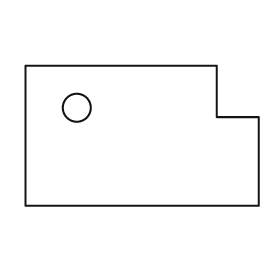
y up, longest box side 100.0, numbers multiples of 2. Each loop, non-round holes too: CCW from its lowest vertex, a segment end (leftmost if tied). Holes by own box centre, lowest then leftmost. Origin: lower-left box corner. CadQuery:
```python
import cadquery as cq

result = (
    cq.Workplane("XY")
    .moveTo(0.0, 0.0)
    .lineTo(100.0, 0.0)
    .lineTo(100.0, 38.0)
    .lineTo(82.0, 38.0)
    .lineTo(82.0, 60.0)
    .lineTo(0.0, 60.0)
    .close()
    .moveTo(22.0, 42.0)
    .circle(6.0)
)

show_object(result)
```